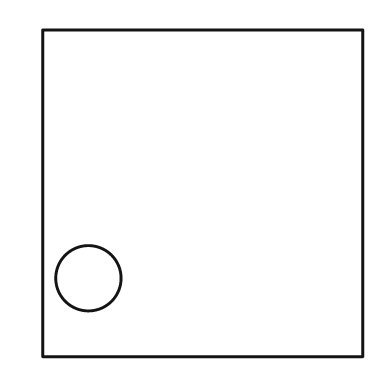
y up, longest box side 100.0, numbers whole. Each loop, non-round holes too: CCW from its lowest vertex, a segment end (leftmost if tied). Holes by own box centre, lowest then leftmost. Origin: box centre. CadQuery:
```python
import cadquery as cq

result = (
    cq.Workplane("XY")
    .moveTo(-49.0, -50.0)
    .lineTo(49.0, -50.0)
    .lineTo(49.0, 50.0)
    .lineTo(-49.0, 50.0)
    .close()
    .moveTo(-35.0, -26.0)
    .circle(10.0)
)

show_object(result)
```